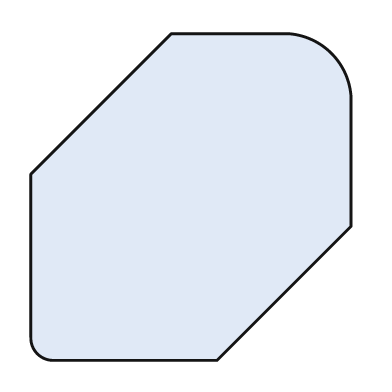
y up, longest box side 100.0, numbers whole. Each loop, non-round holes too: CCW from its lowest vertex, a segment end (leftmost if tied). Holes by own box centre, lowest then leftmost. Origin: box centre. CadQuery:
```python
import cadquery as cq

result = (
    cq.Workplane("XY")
    .moveTo(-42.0, -50.0)
    .lineTo(8.0, -50.0)
    .lineTo(49.0, -9.0)
    .lineTo(49.0, 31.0)
    .threePointArc((43.0, 44.0), (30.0, 50.0))
    .lineTo(-6.0, 50.0)
    .lineTo(-49.0, 7.0)
    .lineTo(-49.0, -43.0)
    .threePointArc((-47.0, -48.0), (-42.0, -50.0))
    .close()
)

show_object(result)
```